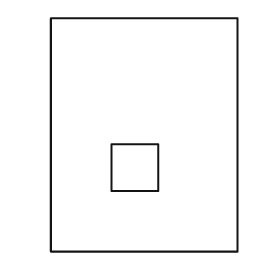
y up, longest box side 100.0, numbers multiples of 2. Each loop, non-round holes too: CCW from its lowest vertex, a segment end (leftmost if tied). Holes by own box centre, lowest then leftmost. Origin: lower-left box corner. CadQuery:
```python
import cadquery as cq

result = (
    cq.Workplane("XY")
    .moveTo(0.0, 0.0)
    .lineTo(80.0, 0.0)
    .lineTo(80.0, 100.0)
    .lineTo(0.0, 100.0)
    .close()
    .moveTo(26.0, 26.0)
    .lineTo(46.0, 26.0)
    .lineTo(46.0, 46.0)
    .lineTo(26.0, 46.0)
    .close()
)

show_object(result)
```